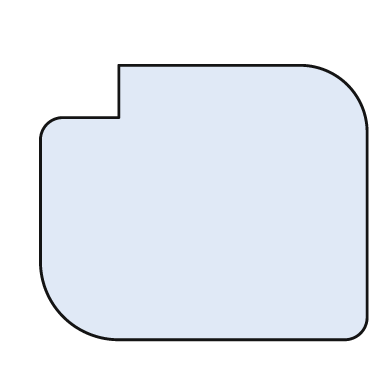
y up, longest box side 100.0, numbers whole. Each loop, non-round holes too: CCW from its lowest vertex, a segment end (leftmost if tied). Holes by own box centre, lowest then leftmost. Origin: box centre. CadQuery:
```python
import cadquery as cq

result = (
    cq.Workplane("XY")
    .moveTo(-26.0, -42.0)
    .lineTo(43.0, -42.0)
    .threePointArc((48.0, -40.0), (50.0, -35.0))
    .lineTo(50.0, 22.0)
    .threePointArc((44.0, 36.0), (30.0, 42.0))
    .lineTo(-26.0, 42.0)
    .lineTo(-26.0, 26.0)
    .lineTo(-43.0, 26.0)
    .threePointArc((-48.0, 24.0), (-50.0, 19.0))
    .lineTo(-50.0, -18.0)
    .threePointArc((-43.0, -35.0), (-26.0, -42.0))
    .close()
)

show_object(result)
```